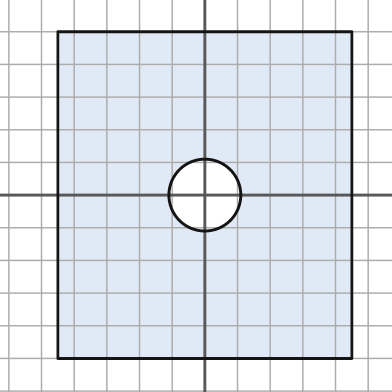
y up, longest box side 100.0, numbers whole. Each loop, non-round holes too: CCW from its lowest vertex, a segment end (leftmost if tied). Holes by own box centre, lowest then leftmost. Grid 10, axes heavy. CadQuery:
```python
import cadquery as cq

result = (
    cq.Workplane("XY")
    .moveTo(-45.0, -50.0)
    .lineTo(45.0, -50.0)
    .lineTo(45.0, 50.0)
    .lineTo(-45.0, 50.0)
    .close()
    .moveTo(0.0, 0.0)
    .circle(11.0)
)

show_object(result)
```